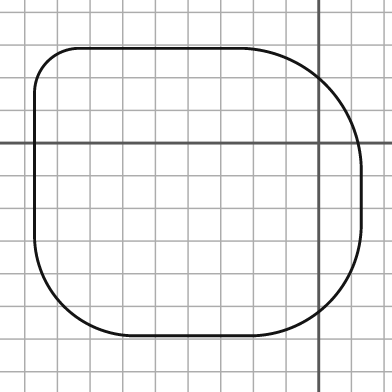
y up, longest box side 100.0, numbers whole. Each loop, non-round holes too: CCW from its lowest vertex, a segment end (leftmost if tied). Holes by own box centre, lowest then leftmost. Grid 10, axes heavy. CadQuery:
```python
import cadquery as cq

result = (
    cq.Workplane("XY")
    .moveTo(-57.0, -59.0)
    .lineTo(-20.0, -59.0)
    .threePointArc((3.0, -49.0), (13.0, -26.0))
    .lineTo(13.0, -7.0)
    .threePointArc((2.0, 18.0), (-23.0, 29.0))
    .lineTo(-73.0, 29.0)
    .threePointArc((-83.0, 25.0), (-87.0, 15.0))
    .lineTo(-87.0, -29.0)
    .threePointArc((-78.0, -50.0), (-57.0, -59.0))
    .close()
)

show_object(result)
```